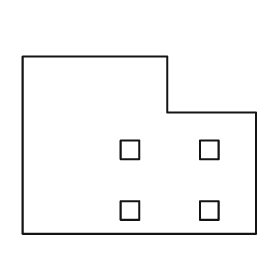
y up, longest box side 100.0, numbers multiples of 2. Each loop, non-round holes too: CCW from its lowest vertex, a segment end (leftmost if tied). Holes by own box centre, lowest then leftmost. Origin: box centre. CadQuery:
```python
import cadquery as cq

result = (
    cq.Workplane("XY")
    .moveTo(-50.0, -38.0)
    .lineTo(50.0, -38.0)
    .lineTo(50.0, 14.0)
    .lineTo(12.0, 14.0)
    .lineTo(12.0, 38.0)
    .lineTo(-50.0, 38.0)
    .close()
    .moveTo(-8.0, -32.0)
    .lineTo(0.0, -32.0)
    .lineTo(0.0, -24.0)
    .lineTo(-8.0, -24.0)
    .close()
    .moveTo(26.0, -32.0)
    .lineTo(34.0, -32.0)
    .lineTo(34.0, -24.0)
    .lineTo(26.0, -24.0)
    .close()
    .moveTo(-8.0, -6.0)
    .lineTo(0.0, -6.0)
    .lineTo(0.0, 2.0)
    .lineTo(-8.0, 2.0)
    .close()
    .moveTo(26.0, -6.0)
    .lineTo(34.0, -6.0)
    .lineTo(34.0, 2.0)
    .lineTo(26.0, 2.0)
    .close()
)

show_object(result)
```